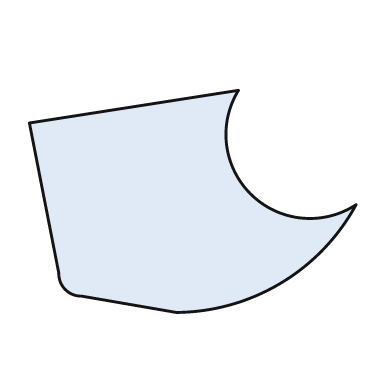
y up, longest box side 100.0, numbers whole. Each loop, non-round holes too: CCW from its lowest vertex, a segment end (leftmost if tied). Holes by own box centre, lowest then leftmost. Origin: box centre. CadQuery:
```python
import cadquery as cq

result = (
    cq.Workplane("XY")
    .moveTo(-5.0, -34.0)
    .threePointArc((27.0, -25.0), (50.0, -1.0))
    .threePointArc((18.0, 2.0), (14.0, 34.0))
    .lineTo(-50.0, 24.0)
    .lineTo(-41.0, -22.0)
    .threePointArc((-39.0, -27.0), (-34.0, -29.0))
    .close()
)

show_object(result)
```